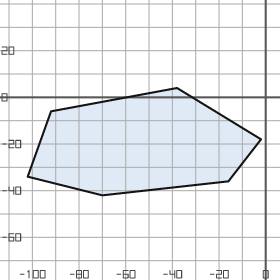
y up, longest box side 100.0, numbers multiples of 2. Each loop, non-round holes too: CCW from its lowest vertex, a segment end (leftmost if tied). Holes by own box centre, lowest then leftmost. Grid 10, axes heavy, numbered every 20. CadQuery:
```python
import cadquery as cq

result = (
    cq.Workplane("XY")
    .moveTo(-70.0, -42.0)
    .lineTo(-16.0, -36.0)
    .lineTo(-2.0, -18.0)
    .lineTo(-38.0, 4.0)
    .lineTo(-92.0, -6.0)
    .lineTo(-102.0, -34.0)
    .close()
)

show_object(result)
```